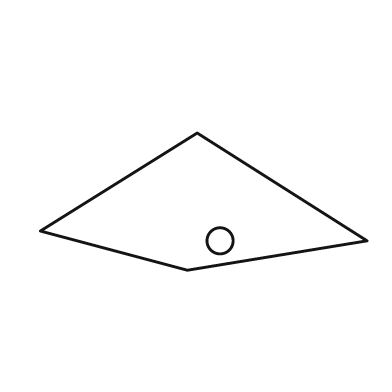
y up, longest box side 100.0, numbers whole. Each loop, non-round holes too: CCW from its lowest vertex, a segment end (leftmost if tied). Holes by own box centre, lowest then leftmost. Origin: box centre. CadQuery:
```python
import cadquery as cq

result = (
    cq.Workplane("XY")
    .moveTo(-5.0, -21.0)
    .lineTo(50.0, -12.0)
    .lineTo(-2.0, 21.0)
    .lineTo(-50.0, -9.0)
    .close()
    .moveTo(5.0, -12.0)
    .circle(4.0)
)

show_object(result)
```